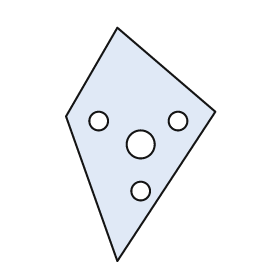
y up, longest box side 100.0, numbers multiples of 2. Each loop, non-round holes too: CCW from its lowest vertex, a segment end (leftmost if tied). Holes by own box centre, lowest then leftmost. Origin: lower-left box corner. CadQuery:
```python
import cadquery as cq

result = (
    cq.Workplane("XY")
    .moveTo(22.0, 0.0)
    .lineTo(64.0, 64.0)
    .lineTo(22.0, 100.0)
    .lineTo(0.0, 62.0)
    .close()
    .moveTo(32.0, 30.0)
    .circle(4.0)
    .moveTo(32.0, 50.0)
    .circle(6.0)
    .moveTo(14.0, 60.0)
    .circle(4.0)
    .moveTo(48.0, 60.0)
    .circle(4.0)
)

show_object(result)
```